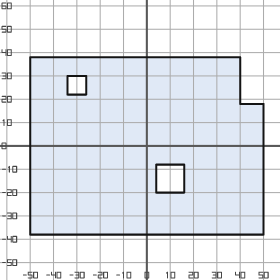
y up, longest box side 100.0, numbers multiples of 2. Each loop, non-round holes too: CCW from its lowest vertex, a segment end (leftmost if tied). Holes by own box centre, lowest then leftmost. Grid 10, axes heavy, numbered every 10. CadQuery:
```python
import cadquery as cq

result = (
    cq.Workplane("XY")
    .moveTo(-50.0, -38.0)
    .lineTo(50.0, -38.0)
    .lineTo(50.0, 18.0)
    .lineTo(40.0, 18.0)
    .lineTo(40.0, 38.0)
    .lineTo(-50.0, 38.0)
    .close()
    .moveTo(4.0, -20.0)
    .lineTo(16.0, -20.0)
    .lineTo(16.0, -8.0)
    .lineTo(4.0, -8.0)
    .close()
    .moveTo(-34.0, 22.0)
    .lineTo(-26.0, 22.0)
    .lineTo(-26.0, 30.0)
    .lineTo(-34.0, 30.0)
    .close()
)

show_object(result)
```